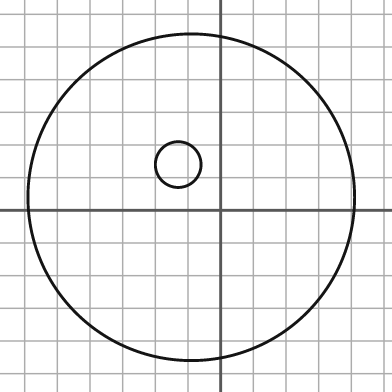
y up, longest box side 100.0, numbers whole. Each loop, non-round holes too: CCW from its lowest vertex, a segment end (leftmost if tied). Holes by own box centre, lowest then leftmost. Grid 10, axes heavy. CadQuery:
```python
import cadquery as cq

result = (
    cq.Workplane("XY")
    .moveTo(-9.0, 4.0)
    .circle(50.0)
    .moveTo(-13.0, 14.0)
    .circle(7.0)
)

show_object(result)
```